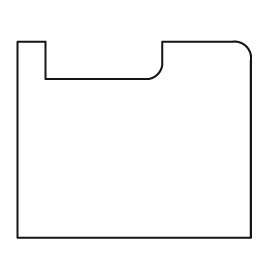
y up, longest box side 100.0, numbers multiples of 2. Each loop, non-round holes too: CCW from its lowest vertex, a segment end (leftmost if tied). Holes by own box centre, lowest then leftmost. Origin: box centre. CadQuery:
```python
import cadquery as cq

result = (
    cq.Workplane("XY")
    .moveTo(-50.0, -42.0)
    .lineTo(50.0, -42.0)
    .lineTo(50.0, 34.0)
    .threePointArc((48.0, 40.0), (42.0, 42.0))
    .lineTo(12.0, 42.0)
    .lineTo(12.0, 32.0)
    .threePointArc((10.0, 28.0), (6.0, 26.0))
    .lineTo(-38.0, 26.0)
    .lineTo(-38.0, 42.0)
    .lineTo(-50.0, 42.0)
    .close()
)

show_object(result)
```